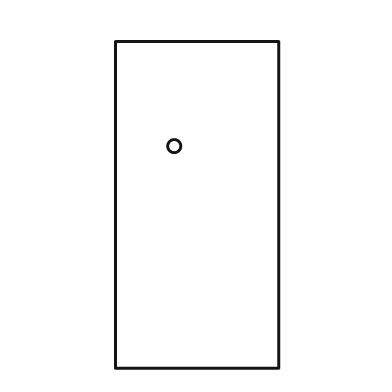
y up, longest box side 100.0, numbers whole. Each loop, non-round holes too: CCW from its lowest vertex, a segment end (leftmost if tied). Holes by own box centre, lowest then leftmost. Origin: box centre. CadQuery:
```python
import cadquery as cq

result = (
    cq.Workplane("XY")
    .moveTo(-25.0, -50.0)
    .lineTo(25.0, -50.0)
    .lineTo(25.0, 50.0)
    .lineTo(-25.0, 50.0)
    .close()
    .moveTo(-7.0, 18.0)
    .circle(2.0)
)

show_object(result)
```